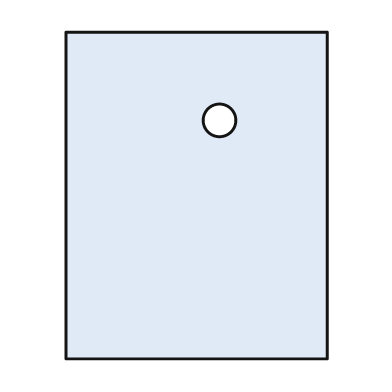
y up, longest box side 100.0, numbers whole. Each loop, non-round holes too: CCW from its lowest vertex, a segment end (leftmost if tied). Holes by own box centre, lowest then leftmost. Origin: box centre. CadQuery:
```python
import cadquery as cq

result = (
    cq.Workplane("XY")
    .moveTo(-40.0, -50.0)
    .lineTo(40.0, -50.0)
    .lineTo(40.0, 50.0)
    .lineTo(-40.0, 50.0)
    .close()
    .moveTo(7.0, 23.0)
    .circle(5.0)
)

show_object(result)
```